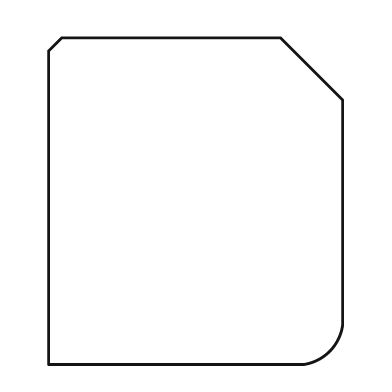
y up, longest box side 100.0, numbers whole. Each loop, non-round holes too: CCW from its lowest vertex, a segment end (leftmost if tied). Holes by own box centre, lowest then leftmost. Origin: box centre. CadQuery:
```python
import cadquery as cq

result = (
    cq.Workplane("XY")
    .moveTo(-45.0, -50.0)
    .lineTo(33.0, -50.0)
    .threePointArc((41.0, -46.0), (45.0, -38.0))
    .lineTo(45.0, 31.0)
    .lineTo(26.0, 50.0)
    .lineTo(-41.0, 50.0)
    .lineTo(-45.0, 46.0)
    .close()
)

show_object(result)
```